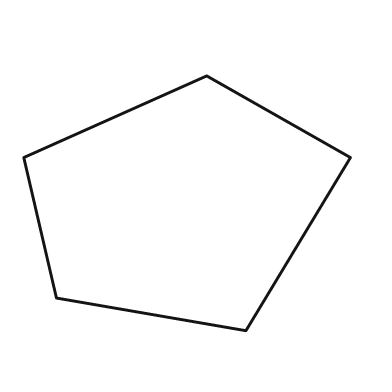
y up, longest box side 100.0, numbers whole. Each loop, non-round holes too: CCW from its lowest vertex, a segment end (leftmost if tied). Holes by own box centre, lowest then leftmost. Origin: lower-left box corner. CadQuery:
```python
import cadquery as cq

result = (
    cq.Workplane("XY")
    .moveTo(68.0, 0.0)
    .lineTo(100.0, 53.0)
    .lineTo(56.0, 78.0)
    .lineTo(0.0, 53.0)
    .lineTo(10.0, 10.0)
    .close()
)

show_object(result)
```